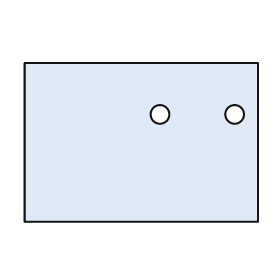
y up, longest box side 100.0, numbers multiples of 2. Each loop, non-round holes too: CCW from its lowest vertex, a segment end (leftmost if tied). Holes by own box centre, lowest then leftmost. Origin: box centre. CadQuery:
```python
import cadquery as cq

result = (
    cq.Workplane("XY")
    .moveTo(-50.0, -34.0)
    .lineTo(50.0, -34.0)
    .lineTo(50.0, 34.0)
    .lineTo(-50.0, 34.0)
    .close()
    .moveTo(8.0, 12.0)
    .circle(4.0)
    .moveTo(40.0, 12.0)
    .circle(4.0)
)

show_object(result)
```